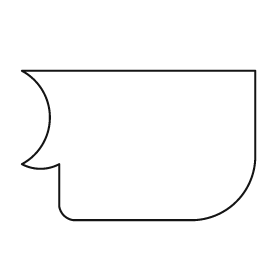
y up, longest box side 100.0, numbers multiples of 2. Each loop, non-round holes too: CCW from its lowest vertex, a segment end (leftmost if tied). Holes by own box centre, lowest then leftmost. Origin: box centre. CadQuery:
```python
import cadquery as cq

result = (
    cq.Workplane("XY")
    .moveTo(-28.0, -32.0)
    .lineTo(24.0, -32.0)
    .threePointArc((42.0, -24.0), (50.0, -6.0))
    .lineTo(50.0, 32.0)
    .lineTo(-50.0, 32.0)
    .threePointArc((-38.0, 12.0), (-50.0, -8.0))
    .threePointArc((-42.0, -10.0), (-34.0, -8.0))
    .lineTo(-34.0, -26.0)
    .threePointArc((-32.0, -30.0), (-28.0, -32.0))
    .close()
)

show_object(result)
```